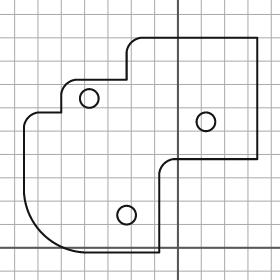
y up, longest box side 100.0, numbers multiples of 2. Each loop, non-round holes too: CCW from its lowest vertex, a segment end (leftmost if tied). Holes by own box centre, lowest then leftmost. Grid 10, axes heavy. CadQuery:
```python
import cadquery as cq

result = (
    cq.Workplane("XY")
    .moveTo(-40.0, -2.0)
    .lineTo(-8.0, -2.0)
    .lineTo(-8.0, 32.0)
    .threePointArc((-6.0, 36.0), (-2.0, 38.0))
    .lineTo(34.0, 38.0)
    .lineTo(34.0, 90.0)
    .lineTo(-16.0, 90.0)
    .threePointArc((-20.0, 88.0), (-22.0, 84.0))
    .lineTo(-22.0, 72.0)
    .lineTo(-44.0, 72.0)
    .threePointArc((-48.0, 70.0), (-50.0, 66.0))
    .lineTo(-50.0, 58.0)
    .lineTo(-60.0, 58.0)
    .threePointArc((-64.0, 56.0), (-66.0, 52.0))
    .lineTo(-66.0, 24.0)
    .threePointArc((-58.0, 6.0), (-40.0, -2.0))
    .close()
    .moveTo(-22.0, 14.0)
    .circle(4.0)
    .moveTo(12.0, 54.0)
    .circle(4.0)
    .moveTo(-38.0, 64.0)
    .circle(4.0)
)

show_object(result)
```